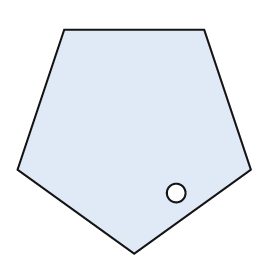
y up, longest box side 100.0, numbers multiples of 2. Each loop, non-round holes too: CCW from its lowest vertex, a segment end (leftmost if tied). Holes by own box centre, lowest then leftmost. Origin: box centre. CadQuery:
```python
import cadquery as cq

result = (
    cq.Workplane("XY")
    .moveTo(0.0, -48.0)
    .lineTo(50.0, -12.0)
    .lineTo(30.0, 48.0)
    .lineTo(-30.0, 48.0)
    .lineTo(-50.0, -12.0)
    .close()
    .moveTo(18.0, -22.0)
    .circle(4.0)
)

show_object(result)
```